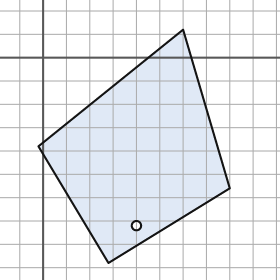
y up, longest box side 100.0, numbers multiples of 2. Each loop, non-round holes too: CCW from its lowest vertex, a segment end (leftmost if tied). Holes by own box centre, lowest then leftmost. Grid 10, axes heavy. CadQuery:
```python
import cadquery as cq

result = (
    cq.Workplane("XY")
    .moveTo(28.0, -88.0)
    .lineTo(80.0, -56.0)
    .lineTo(60.0, 12.0)
    .lineTo(-2.0, -38.0)
    .close()
    .moveTo(40.0, -72.0)
    .circle(2.0)
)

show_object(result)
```